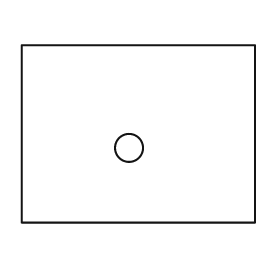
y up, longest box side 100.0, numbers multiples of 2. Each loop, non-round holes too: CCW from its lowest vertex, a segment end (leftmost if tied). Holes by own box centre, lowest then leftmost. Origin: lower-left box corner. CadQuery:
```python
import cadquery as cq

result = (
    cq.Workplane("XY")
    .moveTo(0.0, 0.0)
    .lineTo(100.0, 0.0)
    .lineTo(100.0, 76.0)
    .lineTo(0.0, 76.0)
    .close()
    .moveTo(46.0, 32.0)
    .circle(6.0)
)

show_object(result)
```